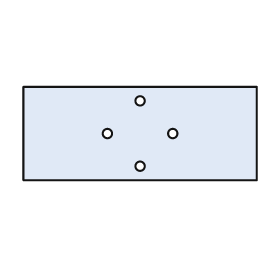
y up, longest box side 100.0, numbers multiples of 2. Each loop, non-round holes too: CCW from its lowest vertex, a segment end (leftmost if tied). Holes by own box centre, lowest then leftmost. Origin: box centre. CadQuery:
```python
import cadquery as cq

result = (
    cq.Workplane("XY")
    .moveTo(-50.0, -20.0)
    .lineTo(50.0, -20.0)
    .lineTo(50.0, 20.0)
    .lineTo(-50.0, 20.0)
    .close()
    .moveTo(0.0, -14.0)
    .circle(2.0)
    .moveTo(-14.0, 0.0)
    .circle(2.0)
    .moveTo(14.0, 0.0)
    .circle(2.0)
    .moveTo(0.0, 14.0)
    .circle(2.0)
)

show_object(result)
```